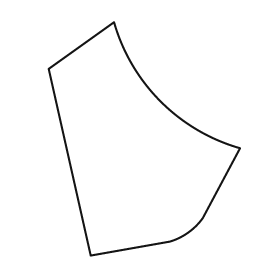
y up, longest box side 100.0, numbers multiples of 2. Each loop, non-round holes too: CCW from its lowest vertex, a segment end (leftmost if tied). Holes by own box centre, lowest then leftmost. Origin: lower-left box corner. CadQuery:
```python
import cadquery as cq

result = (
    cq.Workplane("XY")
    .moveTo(18.0, 0.0)
    .lineTo(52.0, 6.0)
    .threePointArc((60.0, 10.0), (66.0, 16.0))
    .lineTo(82.0, 46.0)
    .threePointArc((48.0, 66.0), (28.0, 100.0))
    .lineTo(0.0, 80.0)
    .close()
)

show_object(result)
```